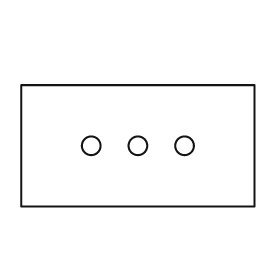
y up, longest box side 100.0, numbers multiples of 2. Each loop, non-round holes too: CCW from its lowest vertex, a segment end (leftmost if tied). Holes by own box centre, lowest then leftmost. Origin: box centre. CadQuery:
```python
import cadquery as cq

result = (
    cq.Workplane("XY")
    .moveTo(-50.0, -26.0)
    .lineTo(50.0, -26.0)
    .lineTo(50.0, 26.0)
    .lineTo(-50.0, 26.0)
    .close()
    .moveTo(-20.0, 0.0)
    .circle(4.0)
    .moveTo(0.0, 0.0)
    .circle(4.0)
    .moveTo(20.0, 0.0)
    .circle(4.0)
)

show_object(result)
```